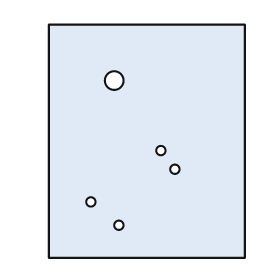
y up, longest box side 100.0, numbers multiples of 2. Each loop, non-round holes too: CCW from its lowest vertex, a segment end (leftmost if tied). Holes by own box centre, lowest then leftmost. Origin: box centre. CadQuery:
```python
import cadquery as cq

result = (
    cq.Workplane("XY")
    .moveTo(-42.0, -50.0)
    .lineTo(42.0, -50.0)
    .lineTo(42.0, 50.0)
    .lineTo(-42.0, 50.0)
    .close()
    .moveTo(-12.0, -36.0)
    .circle(2.0)
    .moveTo(-24.0, -26.0)
    .circle(2.0)
    .moveTo(12.0, -12.0)
    .circle(2.0)
    .moveTo(6.0, -4.0)
    .circle(2.0)
    .moveTo(-14.0, 26.0)
    .circle(4.0)
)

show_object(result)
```